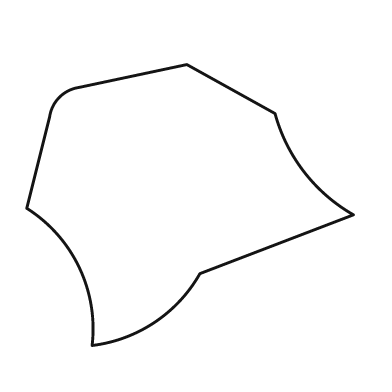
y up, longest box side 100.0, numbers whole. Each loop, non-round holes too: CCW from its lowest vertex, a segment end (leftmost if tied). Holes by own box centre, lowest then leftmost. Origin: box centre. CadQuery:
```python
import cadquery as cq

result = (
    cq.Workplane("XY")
    .moveTo(-30.0, -43.0)
    .threePointArc((-11.0, -36.0), (3.0, -21.0))
    .lineTo(50.0, -3.0)
    .threePointArc((35.0, 10.0), (26.0, 28.0))
    .lineTo(-1.0, 43.0)
    .lineTo(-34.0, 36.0)
    .threePointArc((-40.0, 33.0), (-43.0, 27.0))
    .lineTo(-50.0, -1.0)
    .threePointArc((-34.0, -19.0), (-30.0, -43.0))
    .close()
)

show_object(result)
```